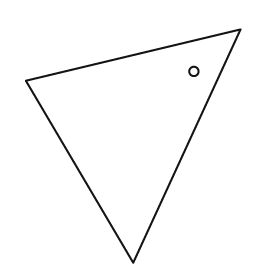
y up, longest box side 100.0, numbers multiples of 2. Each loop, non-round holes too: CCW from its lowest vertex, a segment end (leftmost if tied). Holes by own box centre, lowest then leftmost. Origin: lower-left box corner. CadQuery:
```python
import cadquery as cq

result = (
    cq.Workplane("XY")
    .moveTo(46.0, 0.0)
    .lineTo(92.0, 100.0)
    .lineTo(0.0, 78.0)
    .close()
    .moveTo(72.0, 82.0)
    .circle(2.0)
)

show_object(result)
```